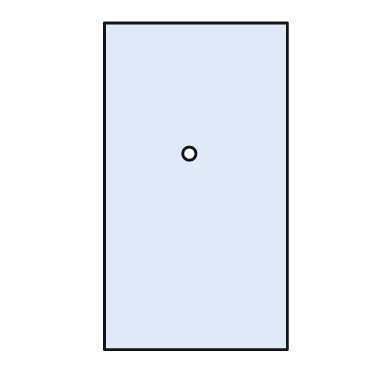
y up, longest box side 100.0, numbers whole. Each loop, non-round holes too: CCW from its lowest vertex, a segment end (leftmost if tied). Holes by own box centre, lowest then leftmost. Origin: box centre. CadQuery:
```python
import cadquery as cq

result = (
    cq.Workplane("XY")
    .moveTo(-28.0, -50.0)
    .lineTo(28.0, -50.0)
    .lineTo(28.0, 50.0)
    .lineTo(-28.0, 50.0)
    .close()
    .moveTo(-2.0, 10.0)
    .circle(2.0)
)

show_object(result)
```